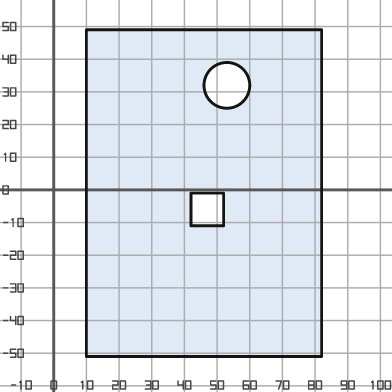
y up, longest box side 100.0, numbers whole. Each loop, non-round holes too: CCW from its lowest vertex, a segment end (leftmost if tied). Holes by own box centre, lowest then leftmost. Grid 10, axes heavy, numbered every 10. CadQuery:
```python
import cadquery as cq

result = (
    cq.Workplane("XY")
    .moveTo(10.0, -51.0)
    .lineTo(82.0, -51.0)
    .lineTo(82.0, 49.0)
    .lineTo(10.0, 49.0)
    .close()
    .moveTo(42.0, -11.0)
    .lineTo(52.0, -11.0)
    .lineTo(52.0, -1.0)
    .lineTo(42.0, -1.0)
    .close()
    .moveTo(53.0, 32.0)
    .circle(7.0)
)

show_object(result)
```